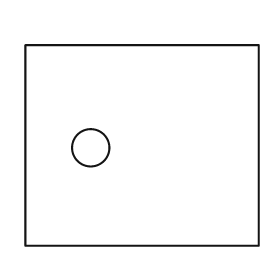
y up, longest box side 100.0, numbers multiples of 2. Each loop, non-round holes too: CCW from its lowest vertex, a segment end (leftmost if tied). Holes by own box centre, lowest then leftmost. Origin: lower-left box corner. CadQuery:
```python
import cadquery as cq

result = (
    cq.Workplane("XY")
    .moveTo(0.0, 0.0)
    .lineTo(100.0, 0.0)
    .lineTo(100.0, 86.0)
    .lineTo(0.0, 86.0)
    .close()
    .moveTo(28.0, 42.0)
    .circle(8.0)
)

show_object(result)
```